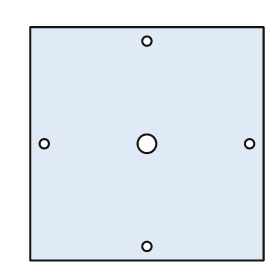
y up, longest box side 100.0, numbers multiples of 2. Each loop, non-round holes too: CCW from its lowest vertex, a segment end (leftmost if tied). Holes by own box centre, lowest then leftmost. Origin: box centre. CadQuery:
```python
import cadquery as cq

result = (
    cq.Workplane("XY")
    .moveTo(-50.0, -50.0)
    .lineTo(50.0, -50.0)
    .lineTo(50.0, 50.0)
    .lineTo(-50.0, 50.0)
    .close()
    .moveTo(0.0, -44.0)
    .circle(2.0)
    .moveTo(-44.0, 0.0)
    .circle(2.0)
    .moveTo(0.0, 0.0)
    .circle(4.0)
    .moveTo(44.0, 0.0)
    .circle(2.0)
    .moveTo(0.0, 44.0)
    .circle(2.0)
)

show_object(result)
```